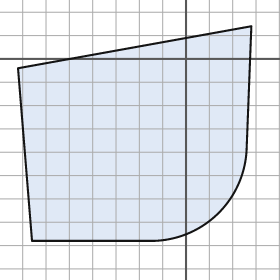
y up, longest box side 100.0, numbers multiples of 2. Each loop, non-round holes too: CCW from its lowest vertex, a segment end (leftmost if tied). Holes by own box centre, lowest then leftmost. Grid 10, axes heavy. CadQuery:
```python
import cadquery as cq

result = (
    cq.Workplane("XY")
    .moveTo(-66.0, -78.0)
    .lineTo(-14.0, -78.0)
    .threePointArc((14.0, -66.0), (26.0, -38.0))
    .lineTo(28.0, 14.0)
    .lineTo(-72.0, -4.0)
    .close()
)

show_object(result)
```